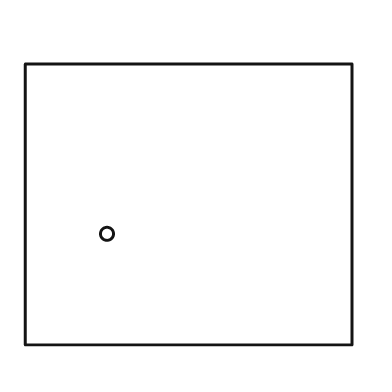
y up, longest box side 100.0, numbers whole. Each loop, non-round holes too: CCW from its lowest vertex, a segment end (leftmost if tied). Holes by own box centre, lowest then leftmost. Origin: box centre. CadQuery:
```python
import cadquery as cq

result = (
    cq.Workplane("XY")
    .moveTo(-50.0, -43.0)
    .lineTo(50.0, -43.0)
    .lineTo(50.0, 43.0)
    .lineTo(-50.0, 43.0)
    .close()
    .moveTo(-25.0, -9.0)
    .circle(2.0)
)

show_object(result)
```